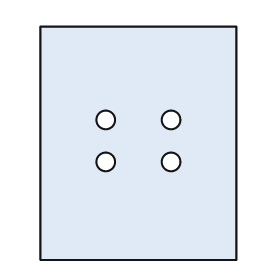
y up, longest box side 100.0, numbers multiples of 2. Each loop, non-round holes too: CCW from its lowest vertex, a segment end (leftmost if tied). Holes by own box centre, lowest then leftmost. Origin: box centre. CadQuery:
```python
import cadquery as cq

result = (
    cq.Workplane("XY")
    .moveTo(-42.0, -50.0)
    .lineTo(42.0, -50.0)
    .lineTo(42.0, 50.0)
    .lineTo(-42.0, 50.0)
    .close()
    .moveTo(-14.0, -8.0)
    .circle(4.0)
    .moveTo(14.0, -8.0)
    .circle(4.0)
    .moveTo(-14.0, 10.0)
    .circle(4.0)
    .moveTo(14.0, 10.0)
    .circle(4.0)
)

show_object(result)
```